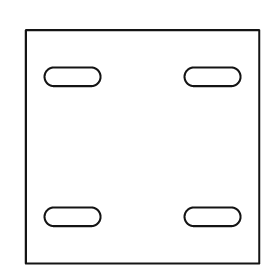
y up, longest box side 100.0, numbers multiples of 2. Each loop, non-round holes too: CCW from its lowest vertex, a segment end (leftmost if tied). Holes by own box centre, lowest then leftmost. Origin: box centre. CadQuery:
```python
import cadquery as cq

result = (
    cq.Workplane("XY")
    .moveTo(-50.0, -50.0)
    .lineTo(50.0, -50.0)
    .lineTo(50.0, 50.0)
    .lineTo(-50.0, 50.0)
    .close()
    .moveTo(-38.0, -34.0)
    .lineTo(-22.0, -34.0)
    .threePointArc((-18.0, -30.0), (-22.0, -26.0))
    .lineTo(-38.0, -26.0)
    .threePointArc((-42.0, -30.0), (-38.0, -34.0))
    .close()
    .moveTo(22.0, -34.0)
    .lineTo(38.0, -34.0)
    .threePointArc((42.0, -30.0), (38.0, -26.0))
    .lineTo(22.0, -26.0)
    .threePointArc((18.0, -30.0), (22.0, -34.0))
    .close()
    .moveTo(-38.0, 26.0)
    .lineTo(-22.0, 26.0)
    .threePointArc((-18.0, 30.0), (-22.0, 34.0))
    .lineTo(-38.0, 34.0)
    .threePointArc((-42.0, 30.0), (-38.0, 26.0))
    .close()
    .moveTo(22.0, 26.0)
    .lineTo(38.0, 26.0)
    .threePointArc((42.0, 30.0), (38.0, 34.0))
    .lineTo(22.0, 34.0)
    .threePointArc((18.0, 30.0), (22.0, 26.0))
    .close()
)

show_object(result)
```